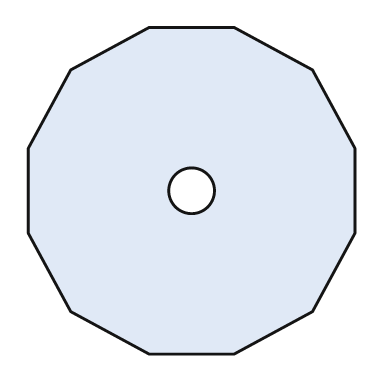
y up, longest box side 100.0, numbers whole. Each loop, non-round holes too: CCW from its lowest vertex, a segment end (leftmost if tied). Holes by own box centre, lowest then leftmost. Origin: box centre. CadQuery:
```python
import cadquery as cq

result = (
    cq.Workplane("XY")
    .moveTo(-13.0, -50.0)
    .lineTo(13.0, -50.0)
    .lineTo(37.0, -37.0)
    .lineTo(50.0, -13.0)
    .lineTo(50.0, 13.0)
    .lineTo(37.0, 37.0)
    .lineTo(13.0, 50.0)
    .lineTo(-13.0, 50.0)
    .lineTo(-37.0, 37.0)
    .lineTo(-50.0, 13.0)
    .lineTo(-50.0, -13.0)
    .lineTo(-37.0, -37.0)
    .close()
    .moveTo(0.0, 0.0)
    .circle(7.0)
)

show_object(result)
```